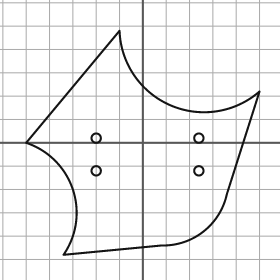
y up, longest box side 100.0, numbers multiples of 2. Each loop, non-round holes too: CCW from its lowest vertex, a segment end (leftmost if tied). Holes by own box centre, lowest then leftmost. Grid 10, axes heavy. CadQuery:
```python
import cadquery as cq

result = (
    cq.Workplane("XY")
    .moveTo(-34.0, -48.0)
    .lineTo(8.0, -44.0)
    .threePointArc((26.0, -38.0), (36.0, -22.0))
    .lineTo(50.0, 22.0)
    .threePointArc((12.0, 16.0), (-10.0, 48.0))
    .lineTo(-50.0, 0.0)
    .threePointArc((-30.0, -20.0), (-34.0, -48.0))
    .close()
    .moveTo(-20.0, -12.0)
    .circle(2.0)
    .moveTo(24.0, -12.0)
    .circle(2.0)
    .moveTo(-20.0, 2.0)
    .circle(2.0)
    .moveTo(24.0, 2.0)
    .circle(2.0)
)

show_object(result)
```